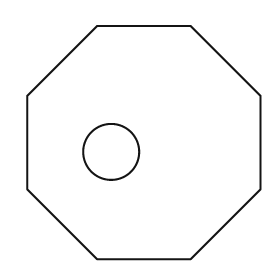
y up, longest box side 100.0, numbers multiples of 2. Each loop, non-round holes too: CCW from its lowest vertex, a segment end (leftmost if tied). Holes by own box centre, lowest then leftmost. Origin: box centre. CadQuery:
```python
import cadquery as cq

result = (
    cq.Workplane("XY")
    .moveTo(-20.0, -50.0)
    .lineTo(20.0, -50.0)
    .lineTo(50.0, -20.0)
    .lineTo(50.0, 20.0)
    .lineTo(20.0, 50.0)
    .lineTo(-20.0, 50.0)
    .lineTo(-50.0, 20.0)
    .lineTo(-50.0, -20.0)
    .close()
    .moveTo(-14.0, -4.0)
    .circle(12.0)
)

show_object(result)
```